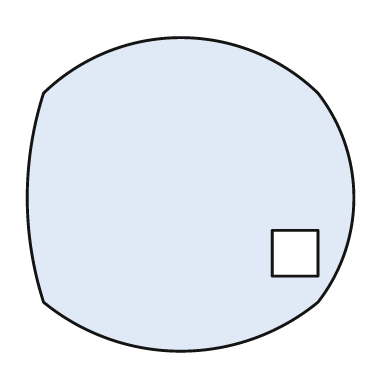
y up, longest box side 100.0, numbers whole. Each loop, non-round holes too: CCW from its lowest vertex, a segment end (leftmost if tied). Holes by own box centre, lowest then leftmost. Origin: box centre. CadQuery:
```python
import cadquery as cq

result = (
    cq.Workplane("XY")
    .moveTo(-45.0, -33.0)
    .threePointArc((-3.0, -48.0), (39.0, -33.0))
    .threePointArc((50.0, -1.0), (39.0, 31.0))
    .threePointArc((-3.0, 48.0), (-45.0, 31.0))
    .threePointArc((-50.0, -1.0), (-45.0, -33.0))
    .close()
    .moveTo(25.0, -25.0)
    .lineTo(39.0, -25.0)
    .lineTo(39.0, -11.0)
    .lineTo(25.0, -11.0)
    .close()
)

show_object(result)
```